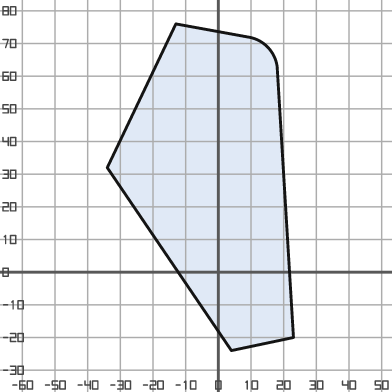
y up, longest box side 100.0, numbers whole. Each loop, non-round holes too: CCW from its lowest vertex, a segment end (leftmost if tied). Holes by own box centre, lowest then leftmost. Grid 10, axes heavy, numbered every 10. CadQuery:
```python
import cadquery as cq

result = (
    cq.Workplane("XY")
    .moveTo(4.0, -24.0)
    .lineTo(23.0, -20.0)
    .lineTo(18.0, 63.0)
    .threePointArc((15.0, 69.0), (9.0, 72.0))
    .lineTo(-13.0, 76.0)
    .lineTo(-34.0, 32.0)
    .close()
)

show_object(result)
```